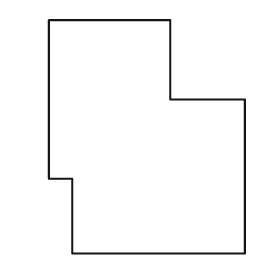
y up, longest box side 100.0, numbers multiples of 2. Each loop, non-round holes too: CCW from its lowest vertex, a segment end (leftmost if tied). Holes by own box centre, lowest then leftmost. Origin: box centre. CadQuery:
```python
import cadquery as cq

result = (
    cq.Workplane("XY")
    .moveTo(-32.0, -50.0)
    .lineTo(42.0, -50.0)
    .lineTo(42.0, 16.0)
    .lineTo(10.0, 16.0)
    .lineTo(10.0, 50.0)
    .lineTo(-42.0, 50.0)
    .lineTo(-42.0, -18.0)
    .lineTo(-32.0, -18.0)
    .close()
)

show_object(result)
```